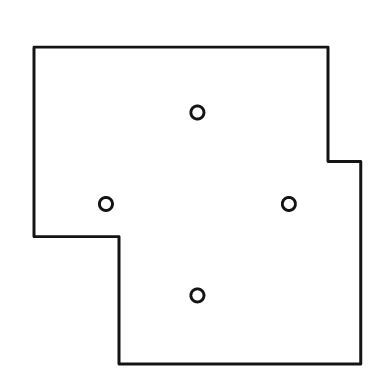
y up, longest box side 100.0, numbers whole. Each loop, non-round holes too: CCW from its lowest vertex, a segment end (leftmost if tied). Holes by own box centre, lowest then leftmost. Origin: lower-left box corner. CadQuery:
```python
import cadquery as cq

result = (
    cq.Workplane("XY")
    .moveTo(26.0, 0.0)
    .lineTo(100.0, 0.0)
    .lineTo(100.0, 62.0)
    .lineTo(90.0, 62.0)
    .lineTo(90.0, 97.0)
    .lineTo(0.0, 97.0)
    .lineTo(0.0, 39.0)
    .lineTo(26.0, 39.0)
    .close()
    .moveTo(50.0, 21.0)
    .circle(2.0)
    .moveTo(22.0, 49.0)
    .circle(2.0)
    .moveTo(78.0, 49.0)
    .circle(2.0)
    .moveTo(50.0, 77.0)
    .circle(2.0)
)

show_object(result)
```